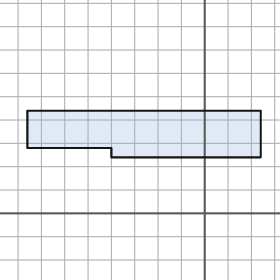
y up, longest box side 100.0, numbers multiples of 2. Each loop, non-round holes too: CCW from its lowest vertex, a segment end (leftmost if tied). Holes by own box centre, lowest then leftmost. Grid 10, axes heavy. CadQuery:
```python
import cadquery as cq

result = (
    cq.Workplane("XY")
    .moveTo(-40.0, 24.0)
    .lineTo(24.0, 24.0)
    .lineTo(24.0, 44.0)
    .lineTo(-76.0, 44.0)
    .lineTo(-76.0, 28.0)
    .lineTo(-40.0, 28.0)
    .close()
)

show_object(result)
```